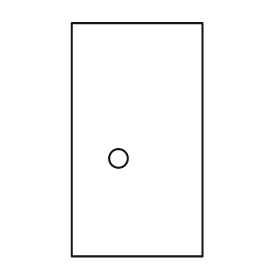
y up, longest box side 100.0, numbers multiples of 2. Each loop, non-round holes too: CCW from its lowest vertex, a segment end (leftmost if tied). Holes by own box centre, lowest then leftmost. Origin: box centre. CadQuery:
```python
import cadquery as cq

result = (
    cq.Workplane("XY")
    .moveTo(-28.0, -50.0)
    .lineTo(28.0, -50.0)
    .lineTo(28.0, 50.0)
    .lineTo(-28.0, 50.0)
    .close()
    .moveTo(-8.0, -8.0)
    .circle(4.0)
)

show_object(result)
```